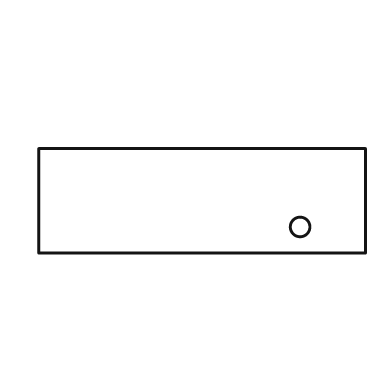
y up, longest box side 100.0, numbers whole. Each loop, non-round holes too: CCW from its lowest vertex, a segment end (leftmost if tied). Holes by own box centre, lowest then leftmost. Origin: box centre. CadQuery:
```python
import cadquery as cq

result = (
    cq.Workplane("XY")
    .moveTo(-50.0, -16.0)
    .lineTo(50.0, -16.0)
    .lineTo(50.0, 16.0)
    .lineTo(-50.0, 16.0)
    .close()
    .moveTo(30.0, -8.0)
    .circle(3.0)
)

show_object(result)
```